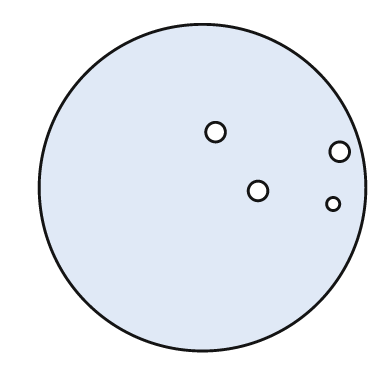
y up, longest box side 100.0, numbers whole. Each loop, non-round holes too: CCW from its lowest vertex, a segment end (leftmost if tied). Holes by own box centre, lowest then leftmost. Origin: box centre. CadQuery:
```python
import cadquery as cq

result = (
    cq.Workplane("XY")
    .moveTo(0.0, 0.0)
    .circle(50.0)
    .moveTo(40.0, -5.0)
    .circle(2.0)
    .moveTo(17.0, -1.0)
    .circle(3.0)
    .moveTo(42.0, 11.0)
    .circle(3.0)
    .moveTo(4.0, 17.0)
    .circle(3.0)
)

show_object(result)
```